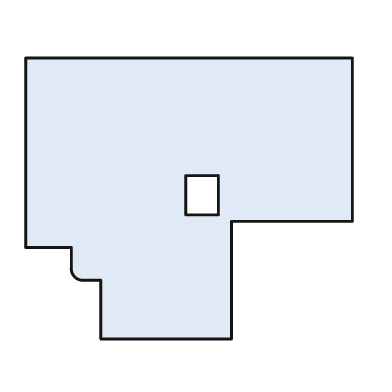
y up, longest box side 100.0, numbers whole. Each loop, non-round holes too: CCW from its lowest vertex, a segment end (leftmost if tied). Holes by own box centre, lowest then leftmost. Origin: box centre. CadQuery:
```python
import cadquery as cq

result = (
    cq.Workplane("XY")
    .moveTo(-27.0, -43.0)
    .lineTo(13.0, -43.0)
    .lineTo(13.0, -7.0)
    .lineTo(50.0, -7.0)
    .lineTo(50.0, 43.0)
    .lineTo(-50.0, 43.0)
    .lineTo(-50.0, -15.0)
    .lineTo(-36.0, -15.0)
    .lineTo(-36.0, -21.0)
    .threePointArc((-35.0, -24.0), (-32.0, -25.0))
    .lineTo(-27.0, -25.0)
    .close()
    .moveTo(-1.0, -5.0)
    .lineTo(9.0, -5.0)
    .lineTo(9.0, 7.0)
    .lineTo(-1.0, 7.0)
    .close()
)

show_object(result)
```